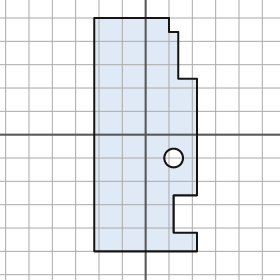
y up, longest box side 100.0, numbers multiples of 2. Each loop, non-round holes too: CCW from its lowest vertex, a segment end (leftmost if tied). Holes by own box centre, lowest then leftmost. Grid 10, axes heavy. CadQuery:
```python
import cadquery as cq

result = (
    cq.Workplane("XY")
    .moveTo(-22.0, -50.0)
    .lineTo(22.0, -50.0)
    .lineTo(22.0, -42.0)
    .lineTo(12.0, -42.0)
    .lineTo(12.0, -26.0)
    .lineTo(22.0, -26.0)
    .lineTo(22.0, 24.0)
    .lineTo(14.0, 24.0)
    .lineTo(14.0, 44.0)
    .lineTo(10.0, 44.0)
    .lineTo(10.0, 50.0)
    .lineTo(-22.0, 50.0)
    .close()
    .moveTo(12.0, -10.0)
    .circle(4.0)
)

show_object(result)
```